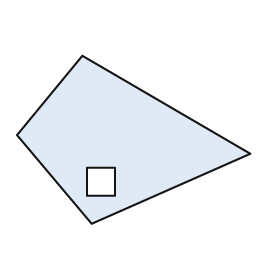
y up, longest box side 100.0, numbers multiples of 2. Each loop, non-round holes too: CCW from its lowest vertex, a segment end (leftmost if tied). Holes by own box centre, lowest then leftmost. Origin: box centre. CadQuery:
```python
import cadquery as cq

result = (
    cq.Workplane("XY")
    .moveTo(-18.0, -36.0)
    .lineTo(50.0, -6.0)
    .lineTo(-22.0, 36.0)
    .lineTo(-50.0, 2.0)
    .close()
    .moveTo(-20.0, -24.0)
    .lineTo(-8.0, -24.0)
    .lineTo(-8.0, -12.0)
    .lineTo(-20.0, -12.0)
    .close()
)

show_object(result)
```